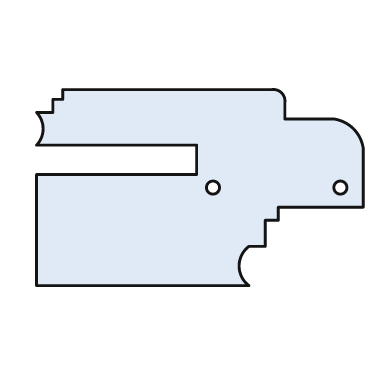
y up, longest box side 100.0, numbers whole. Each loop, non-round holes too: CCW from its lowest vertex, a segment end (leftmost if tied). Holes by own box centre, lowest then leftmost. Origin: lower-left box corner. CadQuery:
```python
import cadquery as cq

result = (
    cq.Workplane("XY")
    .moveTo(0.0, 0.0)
    .lineTo(65.0, 0.0)
    .threePointArc((62.0, 6.0), (65.0, 12.0))
    .lineTo(70.0, 12.0)
    .lineTo(70.0, 20.0)
    .lineTo(74.0, 20.0)
    .lineTo(74.0, 24.0)
    .lineTo(100.0, 24.0)
    .lineTo(100.0, 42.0)
    .threePointArc((97.0, 48.0), (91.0, 51.0))
    .lineTo(76.0, 51.0)
    .lineTo(76.0, 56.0)
    .threePointArc((75.0, 59.0), (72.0, 60.0))
    .lineTo(8.0, 60.0)
    .lineTo(8.0, 57.0)
    .lineTo(5.0, 57.0)
    .lineTo(5.0, 53.0)
    .lineTo(0.0, 53.0)
    .threePointArc((2.0, 48.0), (0.0, 43.0))
    .lineTo(49.0, 43.0)
    .lineTo(49.0, 34.0)
    .lineTo(0.0, 34.0)
    .close()
    .moveTo(54.0, 30.0)
    .circle(2.0)
    .moveTo(93.0, 30.0)
    .circle(2.0)
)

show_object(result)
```